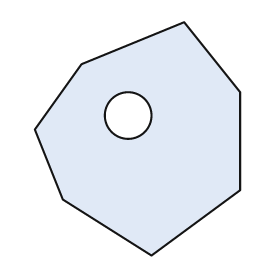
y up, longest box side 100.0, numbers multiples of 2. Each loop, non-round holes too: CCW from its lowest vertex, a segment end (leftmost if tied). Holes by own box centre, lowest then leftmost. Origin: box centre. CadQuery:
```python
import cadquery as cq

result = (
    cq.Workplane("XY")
    .moveTo(6.0, -50.0)
    .lineTo(44.0, -22.0)
    .lineTo(44.0, 20.0)
    .lineTo(20.0, 50.0)
    .lineTo(-24.0, 32.0)
    .lineTo(-44.0, 4.0)
    .lineTo(-32.0, -26.0)
    .close()
    .moveTo(-4.0, 10.0)
    .circle(10.0)
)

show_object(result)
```